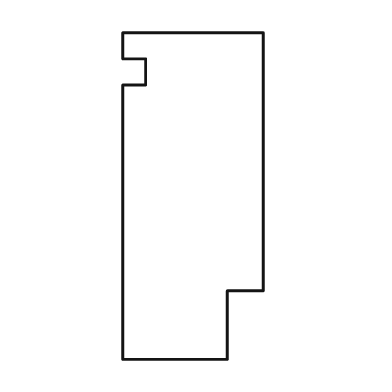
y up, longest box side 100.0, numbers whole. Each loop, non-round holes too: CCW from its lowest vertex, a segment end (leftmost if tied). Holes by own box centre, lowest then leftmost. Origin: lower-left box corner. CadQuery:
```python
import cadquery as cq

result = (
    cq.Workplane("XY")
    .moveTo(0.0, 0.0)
    .lineTo(32.0, 0.0)
    .lineTo(32.0, 21.0)
    .lineTo(43.0, 21.0)
    .lineTo(43.0, 100.0)
    .lineTo(0.0, 100.0)
    .lineTo(0.0, 92.0)
    .lineTo(7.0, 92.0)
    .lineTo(7.0, 84.0)
    .lineTo(0.0, 84.0)
    .close()
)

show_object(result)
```